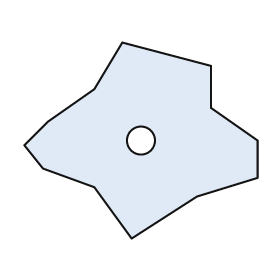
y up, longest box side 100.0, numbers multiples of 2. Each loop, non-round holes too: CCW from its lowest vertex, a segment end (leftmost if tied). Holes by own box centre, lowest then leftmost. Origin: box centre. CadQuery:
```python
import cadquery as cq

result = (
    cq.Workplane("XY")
    .moveTo(-4.0, -42.0)
    .lineTo(24.0, -24.0)
    .lineTo(50.0, -16.0)
    .lineTo(50.0, 0.0)
    .lineTo(30.0, 14.0)
    .lineTo(30.0, 32.0)
    .lineTo(-8.0, 42.0)
    .lineTo(-20.0, 22.0)
    .lineTo(-40.0, 8.0)
    .lineTo(-50.0, -2.0)
    .lineTo(-42.0, -12.0)
    .lineTo(-20.0, -20.0)
    .close()
    .moveTo(0.0, 0.0)
    .circle(6.0)
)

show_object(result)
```